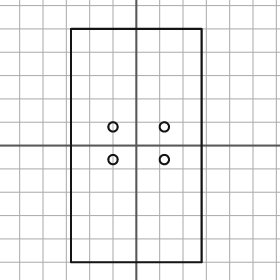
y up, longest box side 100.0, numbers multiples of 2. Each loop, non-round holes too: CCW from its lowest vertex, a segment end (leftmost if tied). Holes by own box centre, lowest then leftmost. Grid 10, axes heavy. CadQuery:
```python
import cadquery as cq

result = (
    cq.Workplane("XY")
    .moveTo(-28.0, -50.0)
    .lineTo(28.0, -50.0)
    .lineTo(28.0, 50.0)
    .lineTo(-28.0, 50.0)
    .close()
    .moveTo(-10.0, -6.0)
    .circle(2.0)
    .moveTo(12.0, -6.0)
    .circle(2.0)
    .moveTo(-10.0, 8.0)
    .circle(2.0)
    .moveTo(12.0, 8.0)
    .circle(2.0)
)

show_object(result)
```